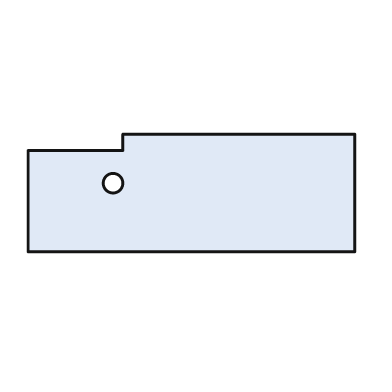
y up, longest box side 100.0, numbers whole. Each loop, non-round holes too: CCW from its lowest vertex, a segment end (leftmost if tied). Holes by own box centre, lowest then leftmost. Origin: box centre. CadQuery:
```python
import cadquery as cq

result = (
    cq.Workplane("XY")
    .moveTo(-50.0, -18.0)
    .lineTo(50.0, -18.0)
    .lineTo(50.0, 18.0)
    .lineTo(-21.0, 18.0)
    .lineTo(-21.0, 13.0)
    .lineTo(-50.0, 13.0)
    .close()
    .moveTo(-24.0, 3.0)
    .circle(3.0)
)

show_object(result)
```